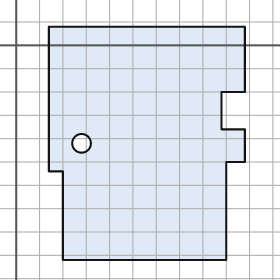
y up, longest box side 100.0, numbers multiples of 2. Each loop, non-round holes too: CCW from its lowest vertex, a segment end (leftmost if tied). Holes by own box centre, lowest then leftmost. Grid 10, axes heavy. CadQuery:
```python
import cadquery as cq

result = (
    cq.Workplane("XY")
    .moveTo(20.0, -92.0)
    .lineTo(90.0, -92.0)
    .lineTo(90.0, -50.0)
    .lineTo(98.0, -50.0)
    .lineTo(98.0, -36.0)
    .lineTo(88.0, -36.0)
    .lineTo(88.0, -20.0)
    .lineTo(98.0, -20.0)
    .lineTo(98.0, 8.0)
    .lineTo(14.0, 8.0)
    .lineTo(14.0, -54.0)
    .lineTo(20.0, -54.0)
    .close()
    .moveTo(28.0, -42.0)
    .circle(4.0)
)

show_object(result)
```